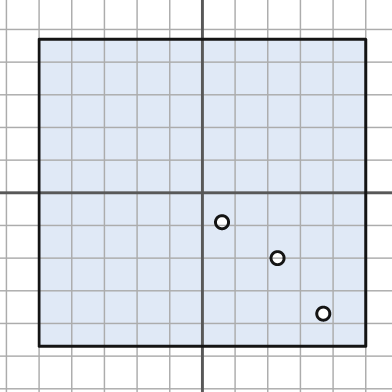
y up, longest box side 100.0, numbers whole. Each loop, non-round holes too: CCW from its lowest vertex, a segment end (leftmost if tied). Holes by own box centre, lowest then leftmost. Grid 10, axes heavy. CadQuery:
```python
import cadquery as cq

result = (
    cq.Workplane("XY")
    .moveTo(-50.0, -47.0)
    .lineTo(50.0, -47.0)
    .lineTo(50.0, 47.0)
    .lineTo(-50.0, 47.0)
    .close()
    .moveTo(37.0, -37.0)
    .circle(2.0)
    .moveTo(23.0, -20.0)
    .circle(2.0)
    .moveTo(6.0, -9.0)
    .circle(2.0)
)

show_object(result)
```